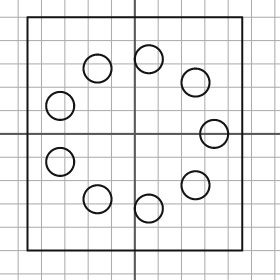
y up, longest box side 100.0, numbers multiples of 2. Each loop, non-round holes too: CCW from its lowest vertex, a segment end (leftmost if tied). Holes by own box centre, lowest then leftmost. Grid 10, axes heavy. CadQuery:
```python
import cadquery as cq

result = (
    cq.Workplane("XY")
    .moveTo(-46.0, -50.0)
    .lineTo(46.0, -50.0)
    .lineTo(46.0, 50.0)
    .lineTo(-46.0, 50.0)
    .close()
    .moveTo(6.0, -32.0)
    .circle(6.0)
    .moveTo(-16.0, -28.0)
    .circle(6.0)
    .moveTo(26.0, -22.0)
    .circle(6.0)
    .moveTo(-32.0, -12.0)
    .circle(6.0)
    .moveTo(34.0, 0.0)
    .circle(6.0)
    .moveTo(-32.0, 12.0)
    .circle(6.0)
    .moveTo(26.0, 22.0)
    .circle(6.0)
    .moveTo(-16.0, 28.0)
    .circle(6.0)
    .moveTo(6.0, 32.0)
    .circle(6.0)
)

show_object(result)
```